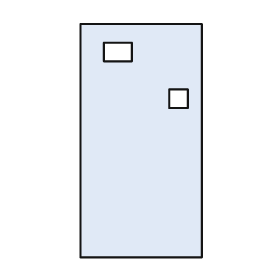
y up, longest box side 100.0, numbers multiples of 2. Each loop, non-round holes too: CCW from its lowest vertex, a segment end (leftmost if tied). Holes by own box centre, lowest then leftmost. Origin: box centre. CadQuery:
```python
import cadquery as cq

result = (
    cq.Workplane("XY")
    .moveTo(-26.0, -50.0)
    .lineTo(26.0, -50.0)
    .lineTo(26.0, 50.0)
    .lineTo(-26.0, 50.0)
    .close()
    .moveTo(12.0, 14.0)
    .lineTo(20.0, 14.0)
    .lineTo(20.0, 22.0)
    .lineTo(12.0, 22.0)
    .close()
    .moveTo(-16.0, 34.0)
    .lineTo(-4.0, 34.0)
    .lineTo(-4.0, 42.0)
    .lineTo(-16.0, 42.0)
    .close()
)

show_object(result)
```